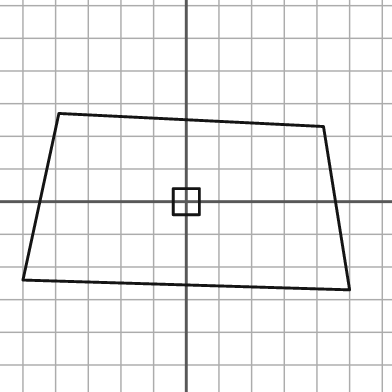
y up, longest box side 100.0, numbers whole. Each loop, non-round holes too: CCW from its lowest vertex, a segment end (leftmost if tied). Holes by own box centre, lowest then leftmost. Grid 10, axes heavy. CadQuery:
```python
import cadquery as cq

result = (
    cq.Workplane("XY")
    .moveTo(50.0, -27.0)
    .lineTo(42.0, 23.0)
    .lineTo(-39.0, 27.0)
    .lineTo(-50.0, -24.0)
    .close()
    .moveTo(-4.0, -4.0)
    .lineTo(4.0, -4.0)
    .lineTo(4.0, 4.0)
    .lineTo(-4.0, 4.0)
    .close()
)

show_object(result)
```